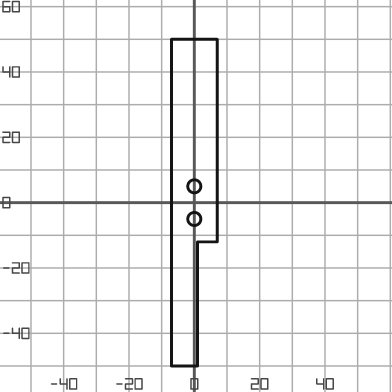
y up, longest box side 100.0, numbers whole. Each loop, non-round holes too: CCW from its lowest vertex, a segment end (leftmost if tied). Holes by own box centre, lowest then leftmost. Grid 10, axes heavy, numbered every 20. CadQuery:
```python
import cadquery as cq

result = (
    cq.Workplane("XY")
    .moveTo(-7.0, -50.0)
    .lineTo(1.0, -50.0)
    .lineTo(1.0, -12.0)
    .lineTo(7.0, -12.0)
    .lineTo(7.0, 50.0)
    .lineTo(-7.0, 50.0)
    .close()
    .moveTo(0.0, -5.0)
    .circle(2.0)
    .moveTo(0.0, 5.0)
    .circle(2.0)
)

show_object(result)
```